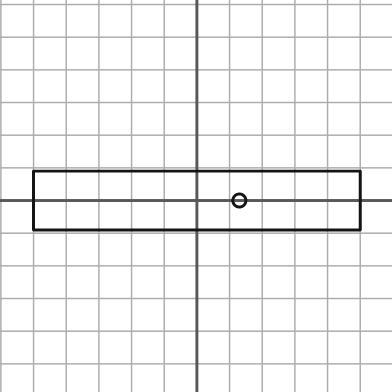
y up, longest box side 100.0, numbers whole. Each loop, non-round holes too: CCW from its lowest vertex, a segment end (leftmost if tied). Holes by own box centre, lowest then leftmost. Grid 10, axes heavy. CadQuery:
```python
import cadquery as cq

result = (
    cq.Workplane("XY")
    .moveTo(-50.0, -9.0)
    .lineTo(50.0, -9.0)
    .lineTo(50.0, 9.0)
    .lineTo(-50.0, 9.0)
    .close()
    .moveTo(13.0, 0.0)
    .circle(2.0)
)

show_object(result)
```